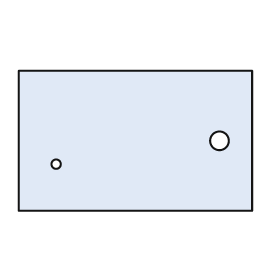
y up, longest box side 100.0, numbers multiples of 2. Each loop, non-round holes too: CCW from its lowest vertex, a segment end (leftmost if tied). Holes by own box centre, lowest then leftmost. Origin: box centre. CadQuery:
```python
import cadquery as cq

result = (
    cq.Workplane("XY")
    .moveTo(-50.0, -30.0)
    .lineTo(50.0, -30.0)
    .lineTo(50.0, 30.0)
    .lineTo(-50.0, 30.0)
    .close()
    .moveTo(-34.0, -10.0)
    .circle(2.0)
    .moveTo(36.0, 0.0)
    .circle(4.0)
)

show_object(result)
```